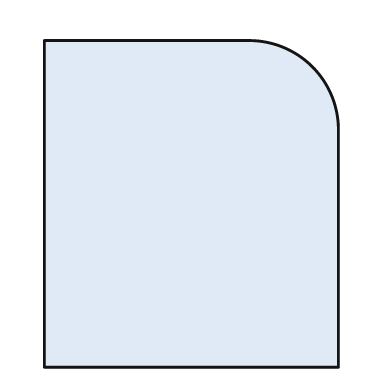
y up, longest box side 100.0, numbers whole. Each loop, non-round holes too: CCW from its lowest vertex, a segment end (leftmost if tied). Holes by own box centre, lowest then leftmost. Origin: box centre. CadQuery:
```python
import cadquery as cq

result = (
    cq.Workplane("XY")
    .moveTo(-45.0, -50.0)
    .lineTo(45.0, -50.0)
    .lineTo(45.0, 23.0)
    .threePointArc((37.0, 42.0), (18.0, 50.0))
    .lineTo(-45.0, 50.0)
    .close()
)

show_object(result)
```